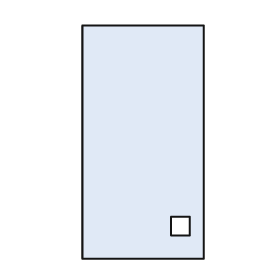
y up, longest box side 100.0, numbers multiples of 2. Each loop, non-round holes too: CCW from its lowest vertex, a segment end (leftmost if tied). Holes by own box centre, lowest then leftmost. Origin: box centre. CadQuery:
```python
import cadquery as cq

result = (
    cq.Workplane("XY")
    .moveTo(-26.0, -50.0)
    .lineTo(26.0, -50.0)
    .lineTo(26.0, 50.0)
    .lineTo(-26.0, 50.0)
    .close()
    .moveTo(12.0, -40.0)
    .lineTo(20.0, -40.0)
    .lineTo(20.0, -32.0)
    .lineTo(12.0, -32.0)
    .close()
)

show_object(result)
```